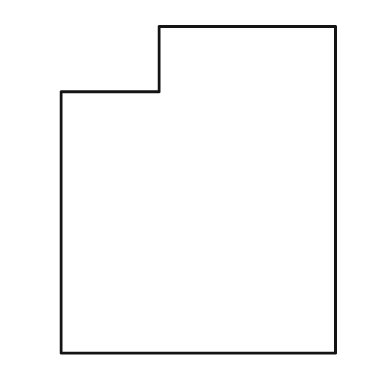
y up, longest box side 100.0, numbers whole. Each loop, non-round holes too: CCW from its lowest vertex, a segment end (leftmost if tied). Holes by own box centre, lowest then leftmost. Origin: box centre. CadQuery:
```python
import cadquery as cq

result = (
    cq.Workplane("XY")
    .moveTo(-42.0, -50.0)
    .lineTo(42.0, -50.0)
    .lineTo(42.0, 50.0)
    .lineTo(-12.0, 50.0)
    .lineTo(-12.0, 30.0)
    .lineTo(-42.0, 30.0)
    .close()
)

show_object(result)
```